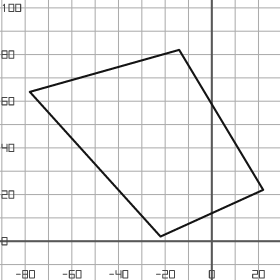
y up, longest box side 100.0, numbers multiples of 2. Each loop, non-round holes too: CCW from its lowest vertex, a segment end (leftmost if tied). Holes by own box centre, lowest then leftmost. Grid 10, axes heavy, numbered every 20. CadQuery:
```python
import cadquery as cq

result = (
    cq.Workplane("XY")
    .moveTo(-22.0, 2.0)
    .lineTo(22.0, 22.0)
    .lineTo(-14.0, 82.0)
    .lineTo(-78.0, 64.0)
    .close()
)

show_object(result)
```